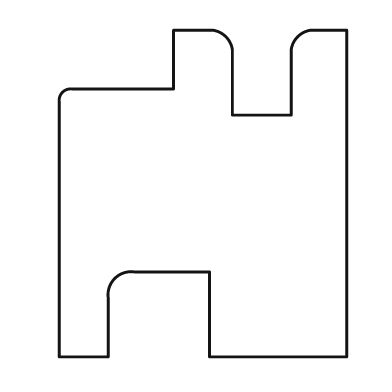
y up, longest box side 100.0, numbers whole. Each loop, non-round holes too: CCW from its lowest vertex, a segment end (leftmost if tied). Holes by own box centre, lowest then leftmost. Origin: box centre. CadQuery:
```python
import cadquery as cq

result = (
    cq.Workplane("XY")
    .moveTo(-44.0, -50.0)
    .lineTo(-29.0, -50.0)
    .lineTo(-29.0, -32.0)
    .threePointArc((-27.0, -26.0), (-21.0, -24.0))
    .lineTo(2.0, -24.0)
    .lineTo(2.0, -50.0)
    .lineTo(44.0, -50.0)
    .lineTo(44.0, 50.0)
    .lineTo(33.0, 50.0)
    .threePointArc((29.0, 48.0), (27.0, 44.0))
    .lineTo(27.0, 24.0)
    .lineTo(9.0, 24.0)
    .lineTo(9.0, 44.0)
    .threePointArc((7.0, 48.0), (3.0, 50.0))
    .lineTo(-9.0, 50.0)
    .lineTo(-9.0, 32.0)
    .lineTo(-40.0, 32.0)
    .threePointArc((-43.0, 31.0), (-44.0, 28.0))
    .close()
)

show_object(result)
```